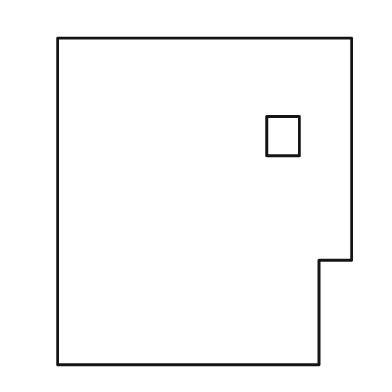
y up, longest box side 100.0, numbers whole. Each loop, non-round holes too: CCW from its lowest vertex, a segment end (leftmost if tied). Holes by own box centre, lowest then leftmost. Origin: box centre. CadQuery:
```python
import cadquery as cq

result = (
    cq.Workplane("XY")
    .moveTo(-45.0, -50.0)
    .lineTo(35.0, -50.0)
    .lineTo(35.0, -18.0)
    .lineTo(45.0, -18.0)
    .lineTo(45.0, 50.0)
    .lineTo(-45.0, 50.0)
    .close()
    .moveTo(19.0, 14.0)
    .lineTo(29.0, 14.0)
    .lineTo(29.0, 26.0)
    .lineTo(19.0, 26.0)
    .close()
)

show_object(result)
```